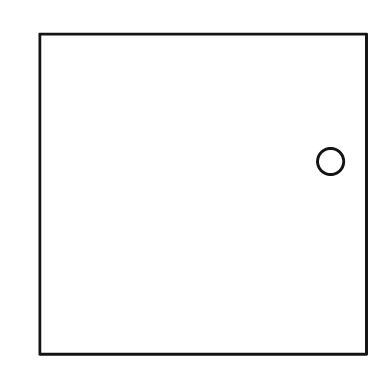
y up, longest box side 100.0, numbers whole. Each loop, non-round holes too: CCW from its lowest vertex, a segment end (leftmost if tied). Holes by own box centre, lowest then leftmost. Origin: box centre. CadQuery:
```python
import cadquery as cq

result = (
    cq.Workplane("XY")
    .moveTo(-50.0, -49.0)
    .lineTo(50.0, -49.0)
    .lineTo(50.0, 49.0)
    .lineTo(-50.0, 49.0)
    .close()
    .moveTo(39.0, 10.0)
    .circle(4.0)
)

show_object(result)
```